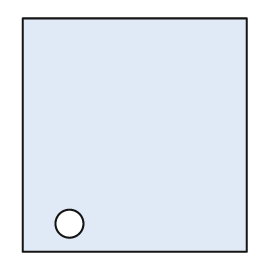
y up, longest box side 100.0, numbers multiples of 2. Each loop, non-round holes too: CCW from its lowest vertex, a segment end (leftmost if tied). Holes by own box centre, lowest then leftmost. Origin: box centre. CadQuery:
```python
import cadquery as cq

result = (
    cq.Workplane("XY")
    .moveTo(-48.0, -50.0)
    .lineTo(48.0, -50.0)
    .lineTo(48.0, 50.0)
    .lineTo(-48.0, 50.0)
    .close()
    .moveTo(-28.0, -38.0)
    .circle(6.0)
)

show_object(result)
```